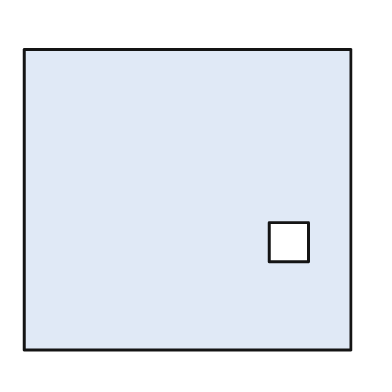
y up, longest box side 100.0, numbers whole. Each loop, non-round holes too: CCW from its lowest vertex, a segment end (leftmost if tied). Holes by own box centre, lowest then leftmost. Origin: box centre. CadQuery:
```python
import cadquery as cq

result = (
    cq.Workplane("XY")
    .moveTo(-50.0, -46.0)
    .lineTo(50.0, -46.0)
    .lineTo(50.0, 46.0)
    .lineTo(-50.0, 46.0)
    .close()
    .moveTo(25.0, -19.0)
    .lineTo(37.0, -19.0)
    .lineTo(37.0, -7.0)
    .lineTo(25.0, -7.0)
    .close()
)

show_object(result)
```